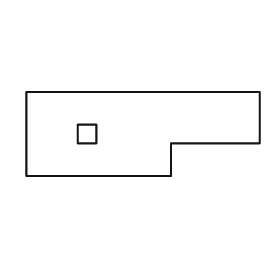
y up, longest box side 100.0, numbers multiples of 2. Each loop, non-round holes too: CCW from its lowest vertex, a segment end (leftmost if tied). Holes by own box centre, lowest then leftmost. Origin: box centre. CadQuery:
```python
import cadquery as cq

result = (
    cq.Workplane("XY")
    .moveTo(-50.0, -18.0)
    .lineTo(12.0, -18.0)
    .lineTo(12.0, -4.0)
    .lineTo(50.0, -4.0)
    .lineTo(50.0, 18.0)
    .lineTo(-50.0, 18.0)
    .close()
    .moveTo(-28.0, -4.0)
    .lineTo(-20.0, -4.0)
    .lineTo(-20.0, 4.0)
    .lineTo(-28.0, 4.0)
    .close()
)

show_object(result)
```